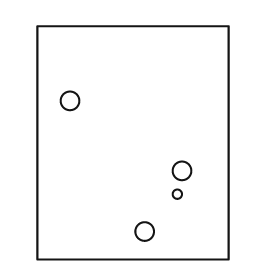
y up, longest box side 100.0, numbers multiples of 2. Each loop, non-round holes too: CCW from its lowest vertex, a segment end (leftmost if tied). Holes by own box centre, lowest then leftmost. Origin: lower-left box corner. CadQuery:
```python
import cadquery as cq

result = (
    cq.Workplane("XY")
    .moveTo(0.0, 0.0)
    .lineTo(82.0, 0.0)
    .lineTo(82.0, 100.0)
    .lineTo(0.0, 100.0)
    .close()
    .moveTo(46.0, 12.0)
    .circle(4.0)
    .moveTo(60.0, 28.0)
    .circle(2.0)
    .moveTo(62.0, 38.0)
    .circle(4.0)
    .moveTo(14.0, 68.0)
    .circle(4.0)
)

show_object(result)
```